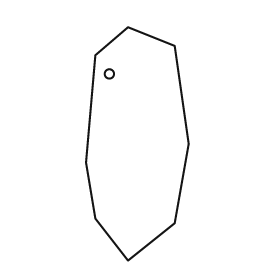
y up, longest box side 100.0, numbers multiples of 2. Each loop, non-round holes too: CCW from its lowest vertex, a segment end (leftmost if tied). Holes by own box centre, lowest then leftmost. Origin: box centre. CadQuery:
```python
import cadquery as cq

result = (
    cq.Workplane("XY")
    .moveTo(-4.0, -50.0)
    .lineTo(16.0, -34.0)
    .lineTo(22.0, 0.0)
    .lineTo(16.0, 42.0)
    .lineTo(-4.0, 50.0)
    .lineTo(-18.0, 38.0)
    .lineTo(-22.0, -8.0)
    .lineTo(-18.0, -32.0)
    .close()
    .moveTo(-12.0, 30.0)
    .circle(2.0)
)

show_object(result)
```